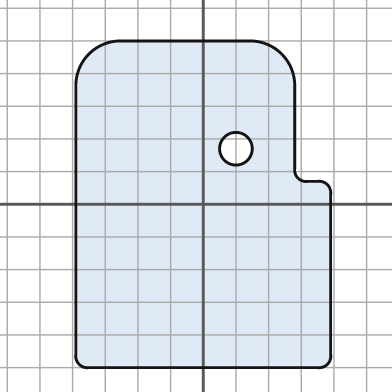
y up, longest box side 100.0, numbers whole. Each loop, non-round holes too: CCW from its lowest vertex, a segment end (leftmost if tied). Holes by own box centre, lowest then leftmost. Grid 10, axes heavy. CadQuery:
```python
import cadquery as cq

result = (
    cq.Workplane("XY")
    .moveTo(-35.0, -50.0)
    .lineTo(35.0, -50.0)
    .threePointArc((38.0, -49.0), (39.0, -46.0))
    .lineTo(39.0, 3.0)
    .threePointArc((38.0, 6.0), (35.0, 7.0))
    .lineTo(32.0, 7.0)
    .threePointArc((29.0, 8.0), (28.0, 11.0))
    .lineTo(28.0, 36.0)
    .threePointArc((24.0, 46.0), (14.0, 50.0))
    .lineTo(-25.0, 50.0)
    .threePointArc((-35.0, 46.0), (-39.0, 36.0))
    .lineTo(-39.0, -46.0)
    .threePointArc((-38.0, -49.0), (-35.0, -50.0))
    .close()
    .moveTo(10.0, 17.0)
    .circle(5.0)
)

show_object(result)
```